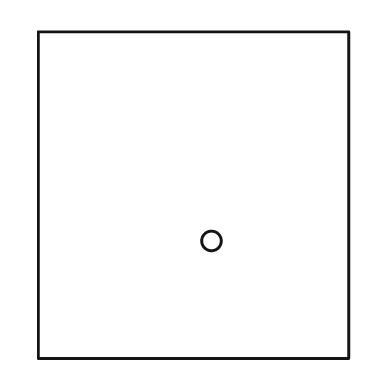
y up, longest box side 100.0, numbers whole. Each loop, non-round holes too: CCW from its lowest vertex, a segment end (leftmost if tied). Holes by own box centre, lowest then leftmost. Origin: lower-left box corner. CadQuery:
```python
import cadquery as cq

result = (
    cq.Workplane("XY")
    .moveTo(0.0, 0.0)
    .lineTo(95.0, 0.0)
    .lineTo(95.0, 100.0)
    .lineTo(0.0, 100.0)
    .close()
    .moveTo(53.0, 36.0)
    .circle(3.0)
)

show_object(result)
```